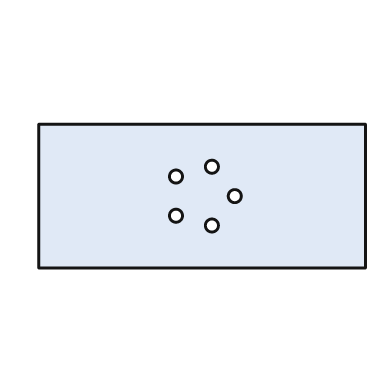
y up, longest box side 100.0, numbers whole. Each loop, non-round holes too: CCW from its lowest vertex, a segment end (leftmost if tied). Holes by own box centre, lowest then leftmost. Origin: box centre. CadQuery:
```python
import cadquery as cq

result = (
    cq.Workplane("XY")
    .moveTo(-50.0, -22.0)
    .lineTo(50.0, -22.0)
    .lineTo(50.0, 22.0)
    .lineTo(-50.0, 22.0)
    .close()
    .moveTo(3.0, -9.0)
    .circle(2.0)
    .moveTo(-8.0, -6.0)
    .circle(2.0)
    .moveTo(10.0, 0.0)
    .circle(2.0)
    .moveTo(-8.0, 6.0)
    .circle(2.0)
    .moveTo(3.0, 9.0)
    .circle(2.0)
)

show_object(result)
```